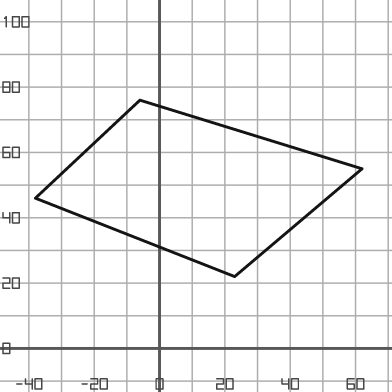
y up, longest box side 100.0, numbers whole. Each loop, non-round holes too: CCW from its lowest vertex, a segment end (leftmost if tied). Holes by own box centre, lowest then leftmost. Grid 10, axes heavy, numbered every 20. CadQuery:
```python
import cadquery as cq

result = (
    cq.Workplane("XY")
    .moveTo(23.0, 22.0)
    .lineTo(62.0, 55.0)
    .lineTo(-6.0, 76.0)
    .lineTo(-38.0, 46.0)
    .close()
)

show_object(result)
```